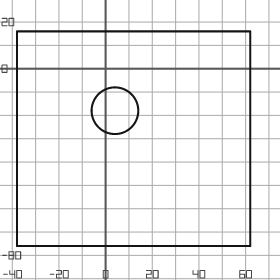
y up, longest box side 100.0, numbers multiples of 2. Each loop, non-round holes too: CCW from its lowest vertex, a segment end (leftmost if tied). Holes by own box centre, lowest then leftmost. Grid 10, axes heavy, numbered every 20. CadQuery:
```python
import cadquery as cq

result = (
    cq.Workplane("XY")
    .moveTo(-38.0, -76.0)
    .lineTo(62.0, -76.0)
    .lineTo(62.0, 16.0)
    .lineTo(-38.0, 16.0)
    .close()
    .moveTo(4.0, -18.0)
    .circle(10.0)
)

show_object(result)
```